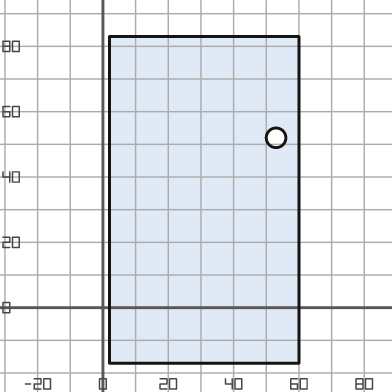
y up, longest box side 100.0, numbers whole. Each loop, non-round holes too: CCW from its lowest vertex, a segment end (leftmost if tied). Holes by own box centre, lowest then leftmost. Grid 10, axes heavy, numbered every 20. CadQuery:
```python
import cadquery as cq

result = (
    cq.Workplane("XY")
    .moveTo(2.0, -17.0)
    .lineTo(60.0, -17.0)
    .lineTo(60.0, 83.0)
    .lineTo(2.0, 83.0)
    .close()
    .moveTo(53.0, 52.0)
    .circle(3.0)
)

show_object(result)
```